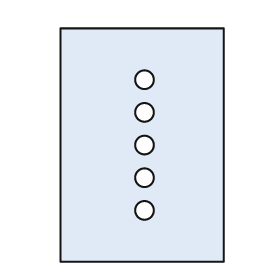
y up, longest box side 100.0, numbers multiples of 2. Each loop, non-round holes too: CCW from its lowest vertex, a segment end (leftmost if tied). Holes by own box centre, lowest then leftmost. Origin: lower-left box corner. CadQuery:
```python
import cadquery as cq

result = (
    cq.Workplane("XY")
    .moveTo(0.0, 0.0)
    .lineTo(70.0, 0.0)
    .lineTo(70.0, 100.0)
    .lineTo(0.0, 100.0)
    .close()
    .moveTo(36.0, 22.0)
    .circle(4.0)
    .moveTo(36.0, 36.0)
    .circle(4.0)
    .moveTo(36.0, 50.0)
    .circle(4.0)
    .moveTo(36.0, 64.0)
    .circle(4.0)
    .moveTo(36.0, 78.0)
    .circle(4.0)
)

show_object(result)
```